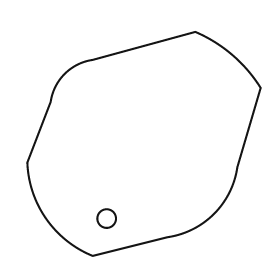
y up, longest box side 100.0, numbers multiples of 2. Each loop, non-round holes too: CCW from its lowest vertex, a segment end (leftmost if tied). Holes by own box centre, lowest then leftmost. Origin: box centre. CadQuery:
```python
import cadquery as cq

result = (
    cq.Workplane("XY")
    .moveTo(-22.0, -48.0)
    .lineTo(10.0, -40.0)
    .threePointArc((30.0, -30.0), (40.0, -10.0))
    .lineTo(50.0, 24.0)
    .threePointArc((38.0, 38.0), (22.0, 48.0))
    .lineTo(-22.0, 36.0)
    .threePointArc((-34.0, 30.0), (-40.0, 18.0))
    .lineTo(-50.0, -8.0)
    .threePointArc((-42.0, -32.0), (-22.0, -48.0))
    .close()
    .moveTo(-16.0, -32.0)
    .circle(4.0)
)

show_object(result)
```